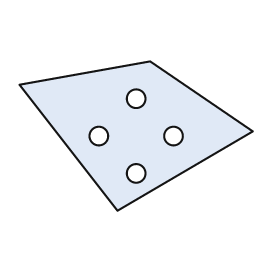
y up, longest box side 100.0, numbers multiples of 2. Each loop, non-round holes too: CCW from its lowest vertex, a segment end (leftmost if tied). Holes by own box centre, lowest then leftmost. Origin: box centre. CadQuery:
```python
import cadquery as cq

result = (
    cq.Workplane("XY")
    .moveTo(-8.0, -32.0)
    .lineTo(50.0, 2.0)
    .lineTo(6.0, 32.0)
    .lineTo(-50.0, 22.0)
    .close()
    .moveTo(0.0, -16.0)
    .circle(4.0)
    .moveTo(-16.0, 0.0)
    .circle(4.0)
    .moveTo(16.0, 0.0)
    .circle(4.0)
    .moveTo(0.0, 16.0)
    .circle(4.0)
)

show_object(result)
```